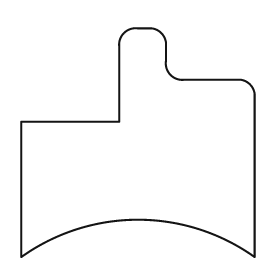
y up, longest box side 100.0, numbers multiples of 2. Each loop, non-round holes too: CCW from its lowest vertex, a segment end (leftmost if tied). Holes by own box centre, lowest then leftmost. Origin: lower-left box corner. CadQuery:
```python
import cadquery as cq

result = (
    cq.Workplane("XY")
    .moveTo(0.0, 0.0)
    .threePointArc((50.0, 16.0), (100.0, 0.0))
    .lineTo(100.0, 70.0)
    .threePointArc((98.0, 74.0), (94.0, 76.0))
    .lineTo(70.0, 76.0)
    .threePointArc((64.0, 78.0), (62.0, 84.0))
    .lineTo(62.0, 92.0)
    .threePointArc((60.0, 96.0), (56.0, 98.0))
    .lineTo(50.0, 98.0)
    .threePointArc((44.0, 96.0), (42.0, 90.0))
    .lineTo(42.0, 58.0)
    .lineTo(0.0, 58.0)
    .close()
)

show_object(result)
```